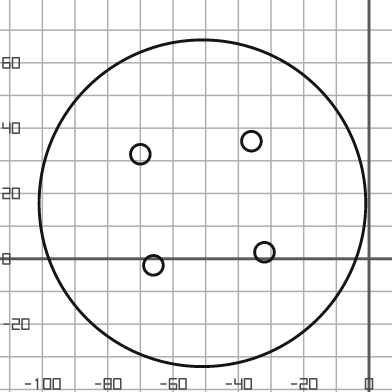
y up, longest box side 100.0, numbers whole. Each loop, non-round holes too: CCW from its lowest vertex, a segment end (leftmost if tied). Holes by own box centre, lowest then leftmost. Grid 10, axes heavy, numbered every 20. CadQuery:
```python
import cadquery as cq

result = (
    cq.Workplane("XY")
    .moveTo(-51.0, 17.0)
    .circle(50.0)
    .moveTo(-66.0, -2.0)
    .circle(3.0)
    .moveTo(-32.0, 2.0)
    .circle(3.0)
    .moveTo(-70.0, 32.0)
    .circle(3.0)
    .moveTo(-36.0, 36.0)
    .circle(3.0)
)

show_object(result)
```